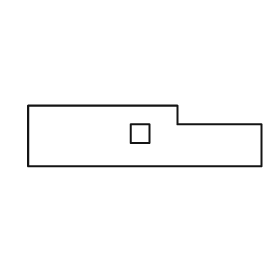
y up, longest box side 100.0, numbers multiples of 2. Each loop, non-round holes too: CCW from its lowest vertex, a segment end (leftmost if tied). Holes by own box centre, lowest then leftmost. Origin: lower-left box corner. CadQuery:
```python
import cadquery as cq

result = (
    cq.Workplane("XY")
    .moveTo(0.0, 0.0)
    .lineTo(100.0, 0.0)
    .lineTo(100.0, 18.0)
    .lineTo(64.0, 18.0)
    .lineTo(64.0, 26.0)
    .lineTo(0.0, 26.0)
    .close()
    .moveTo(44.0, 10.0)
    .lineTo(52.0, 10.0)
    .lineTo(52.0, 18.0)
    .lineTo(44.0, 18.0)
    .close()
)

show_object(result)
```